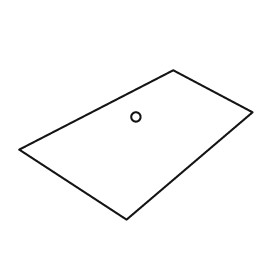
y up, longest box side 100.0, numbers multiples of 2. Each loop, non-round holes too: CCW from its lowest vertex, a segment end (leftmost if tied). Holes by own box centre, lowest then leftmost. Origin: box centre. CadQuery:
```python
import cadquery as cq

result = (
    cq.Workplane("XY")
    .moveTo(-4.0, -32.0)
    .lineTo(50.0, 14.0)
    .lineTo(16.0, 32.0)
    .lineTo(-50.0, -2.0)
    .close()
    .moveTo(0.0, 12.0)
    .circle(2.0)
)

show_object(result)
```